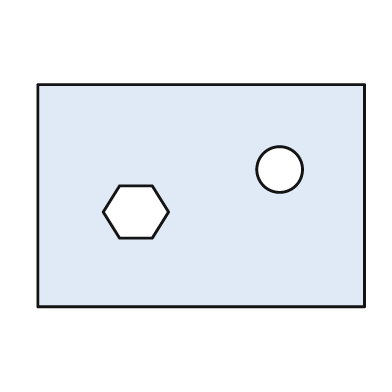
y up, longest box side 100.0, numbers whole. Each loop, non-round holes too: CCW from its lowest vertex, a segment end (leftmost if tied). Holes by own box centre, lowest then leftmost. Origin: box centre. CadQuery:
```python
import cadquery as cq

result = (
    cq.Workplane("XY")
    .moveTo(-50.0, -34.0)
    .lineTo(50.0, -34.0)
    .lineTo(50.0, 34.0)
    .lineTo(-50.0, 34.0)
    .close()
    .moveTo(-25.0, -13.0)
    .lineTo(-15.0, -13.0)
    .lineTo(-10.0, -5.0)
    .lineTo(-15.0, 3.0)
    .lineTo(-25.0, 3.0)
    .lineTo(-30.0, -5.0)
    .close()
    .moveTo(24.0, 8.0)
    .circle(7.0)
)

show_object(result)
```